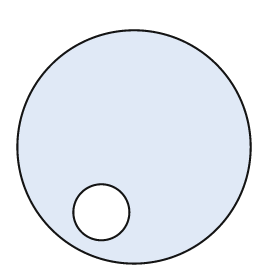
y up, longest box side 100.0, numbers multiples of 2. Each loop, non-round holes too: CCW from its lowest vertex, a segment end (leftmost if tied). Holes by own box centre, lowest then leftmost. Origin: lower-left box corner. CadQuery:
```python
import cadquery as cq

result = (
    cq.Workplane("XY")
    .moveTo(50.0, 50.0)
    .circle(50.0)
    .moveTo(36.0, 22.0)
    .circle(12.0)
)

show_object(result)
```